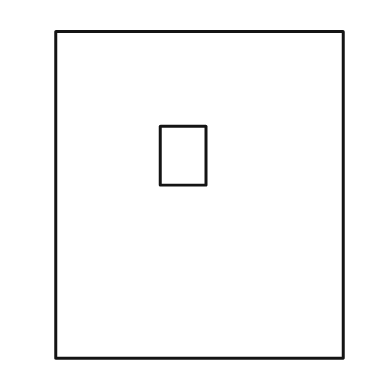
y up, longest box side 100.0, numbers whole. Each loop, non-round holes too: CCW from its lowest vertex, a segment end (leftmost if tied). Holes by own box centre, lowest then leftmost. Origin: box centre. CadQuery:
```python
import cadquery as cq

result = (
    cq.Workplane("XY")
    .moveTo(-44.0, -50.0)
    .lineTo(44.0, -50.0)
    .lineTo(44.0, 50.0)
    .lineTo(-44.0, 50.0)
    .close()
    .moveTo(-12.0, 3.0)
    .lineTo(2.0, 3.0)
    .lineTo(2.0, 21.0)
    .lineTo(-12.0, 21.0)
    .close()
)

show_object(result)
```